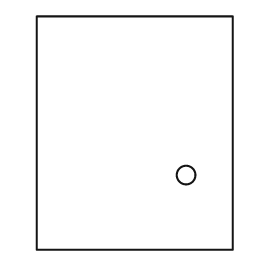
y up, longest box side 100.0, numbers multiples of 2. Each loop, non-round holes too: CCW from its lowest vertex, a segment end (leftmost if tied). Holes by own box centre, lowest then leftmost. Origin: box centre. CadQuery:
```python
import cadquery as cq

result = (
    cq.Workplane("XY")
    .moveTo(-42.0, -50.0)
    .lineTo(42.0, -50.0)
    .lineTo(42.0, 50.0)
    .lineTo(-42.0, 50.0)
    .close()
    .moveTo(22.0, -18.0)
    .circle(4.0)
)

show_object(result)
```